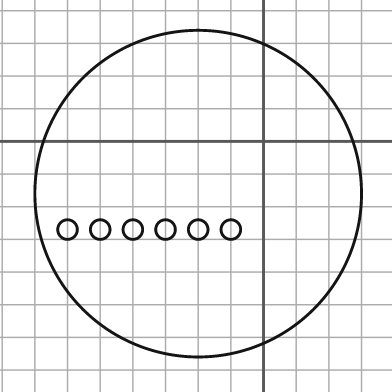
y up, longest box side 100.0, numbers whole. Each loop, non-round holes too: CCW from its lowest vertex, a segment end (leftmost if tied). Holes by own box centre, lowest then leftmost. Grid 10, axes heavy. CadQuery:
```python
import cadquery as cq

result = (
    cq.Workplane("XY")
    .moveTo(-20.0, -16.0)
    .circle(50.0)
    .moveTo(-60.0, -27.0)
    .circle(3.0)
    .moveTo(-50.0, -27.0)
    .circle(3.0)
    .moveTo(-40.0, -27.0)
    .circle(3.0)
    .moveTo(-30.0, -27.0)
    .circle(3.0)
    .moveTo(-20.0, -27.0)
    .circle(3.0)
    .moveTo(-10.0, -27.0)
    .circle(3.0)
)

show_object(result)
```